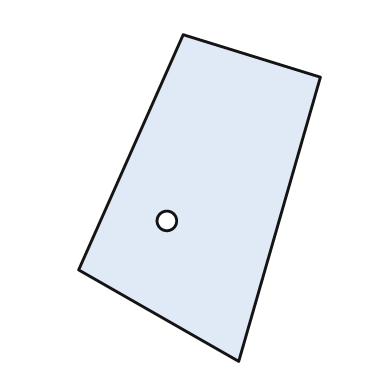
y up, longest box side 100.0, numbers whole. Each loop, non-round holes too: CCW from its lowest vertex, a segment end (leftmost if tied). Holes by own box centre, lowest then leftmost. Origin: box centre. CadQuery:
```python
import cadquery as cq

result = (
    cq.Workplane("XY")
    .moveTo(12.0, -50.0)
    .lineTo(37.0, 37.0)
    .lineTo(-5.0, 50.0)
    .lineTo(-37.0, -22.0)
    .close()
    .moveTo(-10.0, -7.0)
    .circle(3.0)
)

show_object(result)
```